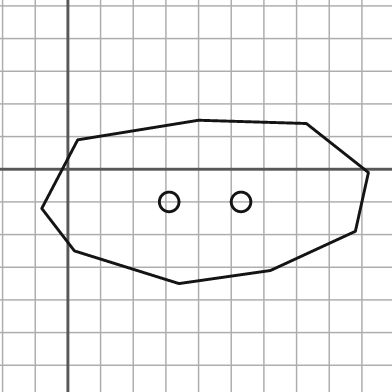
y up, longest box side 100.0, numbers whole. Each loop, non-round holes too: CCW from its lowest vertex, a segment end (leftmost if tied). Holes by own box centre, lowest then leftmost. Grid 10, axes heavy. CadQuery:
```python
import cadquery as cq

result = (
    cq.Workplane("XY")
    .moveTo(34.0, -35.0)
    .lineTo(62.0, -31.0)
    .lineTo(88.0, -19.0)
    .lineTo(92.0, -1.0)
    .lineTo(73.0, 14.0)
    .lineTo(40.0, 15.0)
    .lineTo(3.0, 9.0)
    .lineTo(-8.0, -12.0)
    .lineTo(2.0, -25.0)
    .close()
    .moveTo(31.0, -10.0)
    .circle(3.0)
    .moveTo(53.0, -10.0)
    .circle(3.0)
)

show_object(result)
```